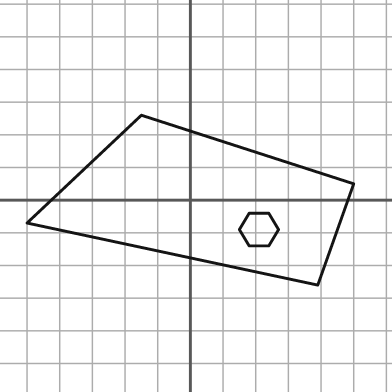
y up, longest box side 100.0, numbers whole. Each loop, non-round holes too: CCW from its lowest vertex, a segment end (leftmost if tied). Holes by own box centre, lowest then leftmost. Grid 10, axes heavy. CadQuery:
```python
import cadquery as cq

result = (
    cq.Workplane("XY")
    .moveTo(39.0, -26.0)
    .lineTo(50.0, 5.0)
    .lineTo(-15.0, 26.0)
    .lineTo(-50.0, -7.0)
    .close()
    .moveTo(18.0, -14.0)
    .lineTo(24.0, -14.0)
    .lineTo(27.0, -9.0)
    .lineTo(24.0, -4.0)
    .lineTo(18.0, -4.0)
    .lineTo(15.0, -9.0)
    .close()
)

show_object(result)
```